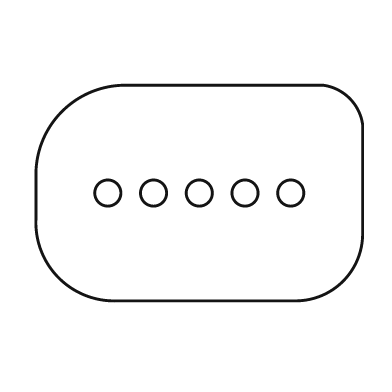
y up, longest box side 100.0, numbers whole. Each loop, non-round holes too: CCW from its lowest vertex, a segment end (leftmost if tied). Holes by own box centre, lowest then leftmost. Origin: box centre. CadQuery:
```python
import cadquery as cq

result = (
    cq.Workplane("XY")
    .moveTo(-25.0, -33.0)
    .lineTo(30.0, -33.0)
    .threePointArc((44.0, -27.0), (50.0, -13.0))
    .lineTo(50.0, 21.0)
    .threePointArc((46.0, 29.0), (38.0, 33.0))
    .lineTo(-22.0, 33.0)
    .threePointArc((-42.0, 25.0), (-50.0, 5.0))
    .lineTo(-50.0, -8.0)
    .threePointArc((-43.0, -26.0), (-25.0, -33.0))
    .close()
    .moveTo(-28.0, 0.0)
    .circle(4.0)
    .moveTo(-14.0, 0.0)
    .circle(4.0)
    .moveTo(0.0, 0.0)
    .circle(4.0)
    .moveTo(14.0, 0.0)
    .circle(4.0)
    .moveTo(28.0, 0.0)
    .circle(4.0)
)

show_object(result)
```